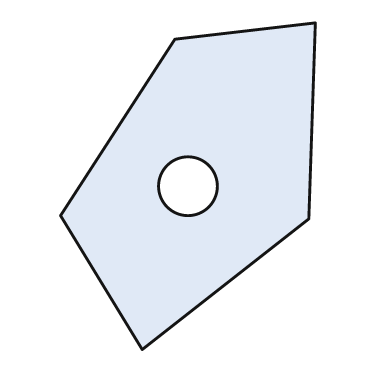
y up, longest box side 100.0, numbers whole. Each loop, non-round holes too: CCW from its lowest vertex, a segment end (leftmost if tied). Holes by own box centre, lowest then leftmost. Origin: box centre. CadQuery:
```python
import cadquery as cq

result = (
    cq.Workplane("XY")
    .moveTo(-14.0, -50.0)
    .lineTo(37.0, -10.0)
    .lineTo(39.0, 50.0)
    .lineTo(-4.0, 45.0)
    .lineTo(-39.0, -9.0)
    .close()
    .moveTo(0.0, 0.0)
    .circle(9.0)
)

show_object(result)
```